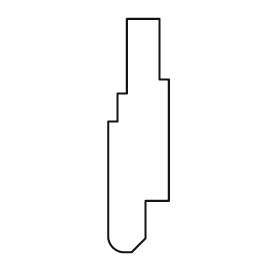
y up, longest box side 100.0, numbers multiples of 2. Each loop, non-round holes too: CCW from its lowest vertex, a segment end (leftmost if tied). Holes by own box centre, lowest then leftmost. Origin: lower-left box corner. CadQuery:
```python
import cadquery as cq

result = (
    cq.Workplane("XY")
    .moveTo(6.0, 0.0)
    .lineTo(10.0, 0.0)
    .lineTo(16.0, 6.0)
    .lineTo(16.0, 22.0)
    .lineTo(26.0, 22.0)
    .lineTo(26.0, 74.0)
    .lineTo(22.0, 74.0)
    .lineTo(22.0, 100.0)
    .lineTo(8.0, 100.0)
    .lineTo(8.0, 68.0)
    .lineTo(4.0, 68.0)
    .lineTo(4.0, 56.0)
    .lineTo(0.0, 56.0)
    .lineTo(0.0, 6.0)
    .threePointArc((2.0, 2.0), (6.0, 0.0))
    .close()
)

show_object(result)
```